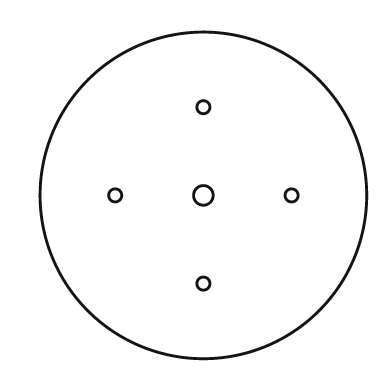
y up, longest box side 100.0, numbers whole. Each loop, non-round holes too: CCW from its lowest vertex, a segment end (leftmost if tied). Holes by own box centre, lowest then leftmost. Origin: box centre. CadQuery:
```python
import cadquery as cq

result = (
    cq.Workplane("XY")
    .moveTo(0.0, 0.0)
    .circle(50.0)
    .moveTo(0.0, -27.0)
    .circle(2.0)
    .moveTo(-27.0, 0.0)
    .circle(2.0)
    .moveTo(0.0, 0.0)
    .circle(3.0)
    .moveTo(27.0, 0.0)
    .circle(2.0)
    .moveTo(0.0, 27.0)
    .circle(2.0)
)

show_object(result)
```